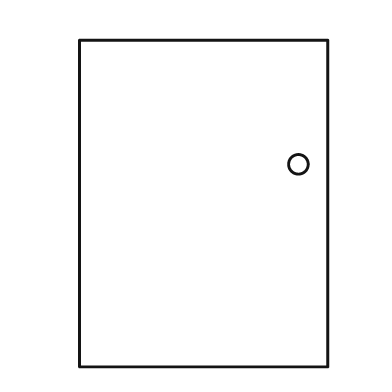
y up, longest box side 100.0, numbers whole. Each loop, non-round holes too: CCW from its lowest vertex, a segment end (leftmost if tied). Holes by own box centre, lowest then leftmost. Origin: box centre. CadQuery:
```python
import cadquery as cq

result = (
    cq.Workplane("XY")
    .moveTo(-38.0, -50.0)
    .lineTo(38.0, -50.0)
    .lineTo(38.0, 50.0)
    .lineTo(-38.0, 50.0)
    .close()
    .moveTo(29.0, 12.0)
    .circle(3.0)
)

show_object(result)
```